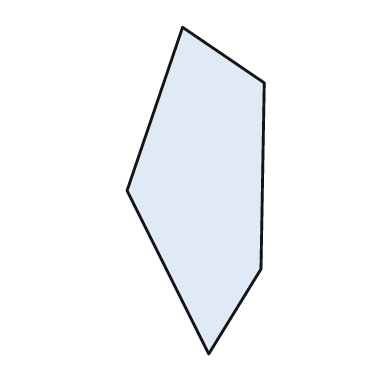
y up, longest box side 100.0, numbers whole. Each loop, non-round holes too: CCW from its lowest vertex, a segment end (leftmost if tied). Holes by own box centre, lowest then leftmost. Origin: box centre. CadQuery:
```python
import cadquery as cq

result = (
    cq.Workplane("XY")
    .moveTo(4.0, -50.0)
    .lineTo(20.0, -24.0)
    .lineTo(21.0, 33.0)
    .lineTo(-4.0, 50.0)
    .lineTo(-21.0, 0.0)
    .close()
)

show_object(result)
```